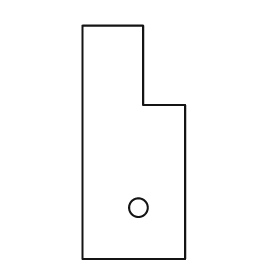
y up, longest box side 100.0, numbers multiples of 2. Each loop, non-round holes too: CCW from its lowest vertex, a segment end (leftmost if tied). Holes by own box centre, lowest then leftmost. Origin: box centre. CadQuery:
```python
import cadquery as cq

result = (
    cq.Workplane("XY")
    .moveTo(-22.0, -50.0)
    .lineTo(22.0, -50.0)
    .lineTo(22.0, 16.0)
    .lineTo(4.0, 16.0)
    .lineTo(4.0, 50.0)
    .lineTo(-22.0, 50.0)
    .close()
    .moveTo(2.0, -28.0)
    .circle(4.0)
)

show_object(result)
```